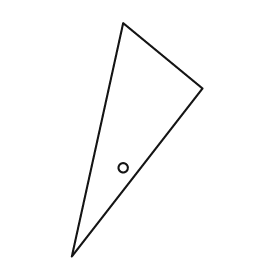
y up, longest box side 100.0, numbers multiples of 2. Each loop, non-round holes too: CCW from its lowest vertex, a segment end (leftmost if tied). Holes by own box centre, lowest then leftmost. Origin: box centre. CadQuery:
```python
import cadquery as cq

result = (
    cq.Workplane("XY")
    .moveTo(-28.0, -50.0)
    .lineTo(28.0, 22.0)
    .lineTo(-6.0, 50.0)
    .close()
    .moveTo(-6.0, -12.0)
    .circle(2.0)
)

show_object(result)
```